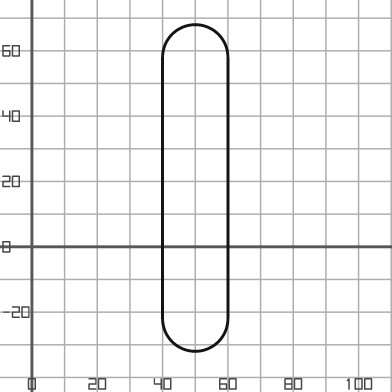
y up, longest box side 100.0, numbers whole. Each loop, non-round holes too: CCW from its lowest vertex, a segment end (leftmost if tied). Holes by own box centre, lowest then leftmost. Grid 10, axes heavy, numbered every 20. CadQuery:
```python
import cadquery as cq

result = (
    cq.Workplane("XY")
    .moveTo(40.0, -22.0)
    .threePointArc((50.0, -32.0), (60.0, -22.0))
    .lineTo(60.0, 58.0)
    .threePointArc((50.0, 68.0), (40.0, 58.0))
    .close()
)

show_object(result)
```